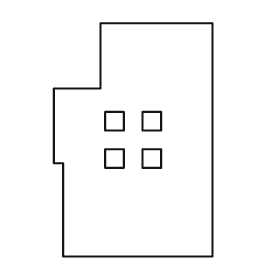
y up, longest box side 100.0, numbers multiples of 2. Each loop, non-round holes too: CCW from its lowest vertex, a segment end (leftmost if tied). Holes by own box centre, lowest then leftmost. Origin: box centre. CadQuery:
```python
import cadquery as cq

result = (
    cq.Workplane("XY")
    .moveTo(-30.0, -50.0)
    .lineTo(34.0, -50.0)
    .lineTo(34.0, 50.0)
    .lineTo(-14.0, 50.0)
    .lineTo(-14.0, 22.0)
    .lineTo(-34.0, 22.0)
    .lineTo(-34.0, -10.0)
    .lineTo(-30.0, -10.0)
    .close()
    .moveTo(-12.0, -12.0)
    .lineTo(-4.0, -12.0)
    .lineTo(-4.0, -4.0)
    .lineTo(-12.0, -4.0)
    .close()
    .moveTo(4.0, -12.0)
    .lineTo(12.0, -12.0)
    .lineTo(12.0, -4.0)
    .lineTo(4.0, -4.0)
    .close()
    .moveTo(-12.0, 4.0)
    .lineTo(-4.0, 4.0)
    .lineTo(-4.0, 12.0)
    .lineTo(-12.0, 12.0)
    .close()
    .moveTo(4.0, 4.0)
    .lineTo(12.0, 4.0)
    .lineTo(12.0, 12.0)
    .lineTo(4.0, 12.0)
    .close()
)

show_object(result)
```